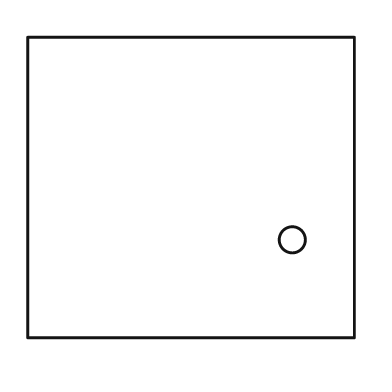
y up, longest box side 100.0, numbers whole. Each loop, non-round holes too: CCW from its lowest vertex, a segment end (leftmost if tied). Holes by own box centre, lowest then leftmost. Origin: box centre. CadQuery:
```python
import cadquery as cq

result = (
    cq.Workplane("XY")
    .moveTo(-50.0, -46.0)
    .lineTo(50.0, -46.0)
    .lineTo(50.0, 46.0)
    .lineTo(-50.0, 46.0)
    .close()
    .moveTo(31.0, -16.0)
    .circle(4.0)
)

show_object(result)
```